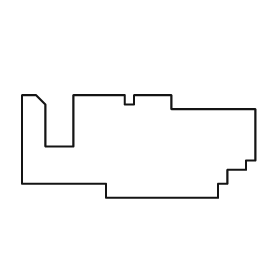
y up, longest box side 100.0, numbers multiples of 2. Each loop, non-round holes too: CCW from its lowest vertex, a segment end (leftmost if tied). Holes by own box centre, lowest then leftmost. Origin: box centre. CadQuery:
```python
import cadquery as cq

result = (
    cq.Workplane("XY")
    .moveTo(-14.0, -22.0)
    .lineTo(34.0, -22.0)
    .lineTo(34.0, -16.0)
    .lineTo(38.0, -16.0)
    .lineTo(38.0, -10.0)
    .lineTo(46.0, -10.0)
    .lineTo(46.0, -6.0)
    .lineTo(50.0, -6.0)
    .lineTo(50.0, 16.0)
    .lineTo(14.0, 16.0)
    .lineTo(14.0, 22.0)
    .lineTo(-2.0, 22.0)
    .lineTo(-2.0, 18.0)
    .lineTo(-6.0, 18.0)
    .lineTo(-6.0, 22.0)
    .lineTo(-28.0, 22.0)
    .lineTo(-28.0, 0.0)
    .lineTo(-40.0, 0.0)
    .lineTo(-40.0, 18.0)
    .lineTo(-44.0, 22.0)
    .lineTo(-50.0, 22.0)
    .lineTo(-50.0, -16.0)
    .lineTo(-14.0, -16.0)
    .close()
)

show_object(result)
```